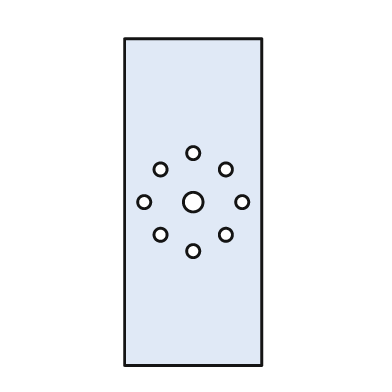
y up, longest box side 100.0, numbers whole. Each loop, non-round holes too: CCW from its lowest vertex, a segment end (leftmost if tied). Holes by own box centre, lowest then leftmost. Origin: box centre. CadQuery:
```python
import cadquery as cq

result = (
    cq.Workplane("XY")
    .moveTo(-21.0, -50.0)
    .lineTo(21.0, -50.0)
    .lineTo(21.0, 50.0)
    .lineTo(-21.0, 50.0)
    .close()
    .moveTo(0.0, -15.0)
    .circle(2.0)
    .moveTo(-10.0, -10.0)
    .circle(2.0)
    .moveTo(10.0, -10.0)
    .circle(2.0)
    .moveTo(-15.0, 0.0)
    .circle(2.0)
    .moveTo(0.0, 0.0)
    .circle(3.0)
    .moveTo(15.0, 0.0)
    .circle(2.0)
    .moveTo(-10.0, 10.0)
    .circle(2.0)
    .moveTo(10.0, 10.0)
    .circle(2.0)
    .moveTo(0.0, 15.0)
    .circle(2.0)
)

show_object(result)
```